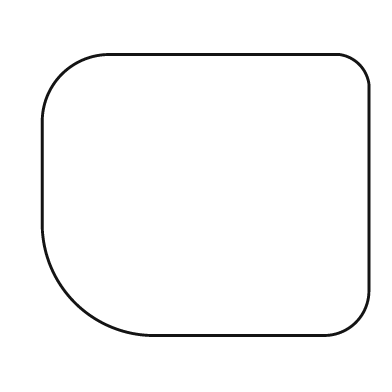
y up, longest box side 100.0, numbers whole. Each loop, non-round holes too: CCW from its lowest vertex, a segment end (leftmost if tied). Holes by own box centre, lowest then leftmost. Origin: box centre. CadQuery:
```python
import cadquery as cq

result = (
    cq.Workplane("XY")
    .moveTo(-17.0, -43.0)
    .lineTo(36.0, -43.0)
    .threePointArc((46.0, -39.0), (50.0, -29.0))
    .lineTo(50.0, 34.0)
    .threePointArc((47.0, 40.0), (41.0, 43.0))
    .lineTo(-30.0, 43.0)
    .threePointArc((-44.0, 37.0), (-50.0, 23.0))
    .lineTo(-50.0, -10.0)
    .threePointArc((-40.0, -33.0), (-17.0, -43.0))
    .close()
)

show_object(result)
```